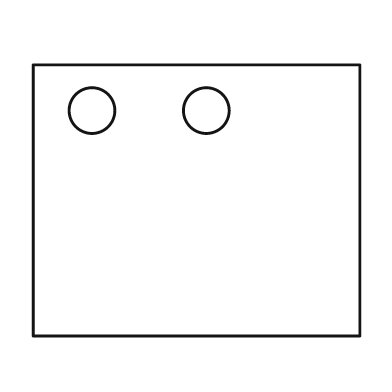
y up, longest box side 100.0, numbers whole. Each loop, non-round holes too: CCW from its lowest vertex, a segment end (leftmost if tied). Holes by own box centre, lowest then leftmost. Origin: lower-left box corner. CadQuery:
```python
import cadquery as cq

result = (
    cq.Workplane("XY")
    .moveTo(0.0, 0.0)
    .lineTo(100.0, 0.0)
    .lineTo(100.0, 83.0)
    .lineTo(0.0, 83.0)
    .close()
    .moveTo(18.0, 69.0)
    .circle(7.0)
    .moveTo(53.0, 69.0)
    .circle(7.0)
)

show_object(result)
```